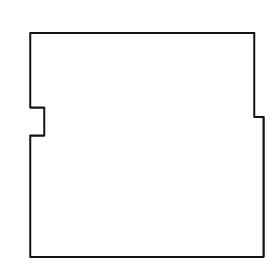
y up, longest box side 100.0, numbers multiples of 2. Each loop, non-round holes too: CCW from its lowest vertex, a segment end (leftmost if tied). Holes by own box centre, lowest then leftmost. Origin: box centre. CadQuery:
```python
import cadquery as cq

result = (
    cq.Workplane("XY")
    .moveTo(-50.0, -48.0)
    .lineTo(50.0, -48.0)
    .lineTo(50.0, 12.0)
    .lineTo(46.0, 12.0)
    .lineTo(46.0, 48.0)
    .lineTo(-50.0, 48.0)
    .lineTo(-50.0, 16.0)
    .lineTo(-44.0, 16.0)
    .lineTo(-44.0, 4.0)
    .lineTo(-50.0, 4.0)
    .close()
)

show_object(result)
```